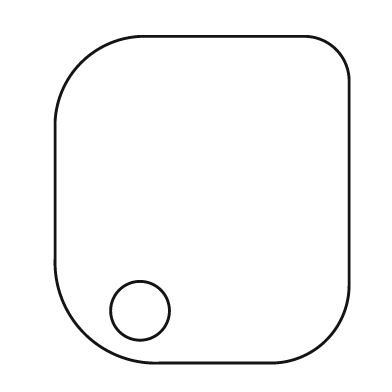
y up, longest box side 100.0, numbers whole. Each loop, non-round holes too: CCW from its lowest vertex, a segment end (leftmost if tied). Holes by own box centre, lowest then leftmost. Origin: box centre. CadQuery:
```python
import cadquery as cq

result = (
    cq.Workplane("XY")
    .moveTo(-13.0, -50.0)
    .lineTo(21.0, -50.0)
    .threePointArc((38.0, -43.0), (45.0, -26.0))
    .lineTo(45.0, 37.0)
    .threePointArc((41.0, 46.0), (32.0, 50.0))
    .lineTo(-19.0, 50.0)
    .threePointArc((-37.0, 42.0), (-45.0, 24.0))
    .lineTo(-45.0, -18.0)
    .threePointArc((-36.0, -41.0), (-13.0, -50.0))
    .close()
    .moveTo(-19.0, -34.0)
    .circle(9.0)
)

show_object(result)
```